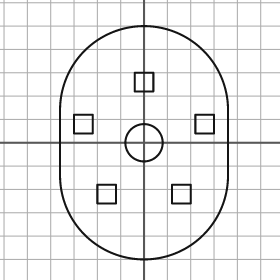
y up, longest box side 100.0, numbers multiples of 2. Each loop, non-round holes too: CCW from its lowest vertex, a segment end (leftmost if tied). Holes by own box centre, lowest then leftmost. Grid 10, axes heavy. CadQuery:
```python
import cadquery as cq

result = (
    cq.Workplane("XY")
    .moveTo(-36.0, -14.0)
    .threePointArc((0.0, -50.0), (36.0, -14.0))
    .lineTo(36.0, 14.0)
    .threePointArc((0.0, 50.0), (-36.0, 14.0))
    .close()
    .moveTo(-20.0, -26.0)
    .lineTo(-12.0, -26.0)
    .lineTo(-12.0, -18.0)
    .lineTo(-20.0, -18.0)
    .close()
    .moveTo(12.0, -26.0)
    .lineTo(20.0, -26.0)
    .lineTo(20.0, -18.0)
    .lineTo(12.0, -18.0)
    .close()
    .moveTo(0.0, 0.0)
    .circle(8.0)
    .moveTo(-30.0, 4.0)
    .lineTo(-22.0, 4.0)
    .lineTo(-22.0, 12.0)
    .lineTo(-30.0, 12.0)
    .close()
    .moveTo(22.0, 4.0)
    .lineTo(30.0, 4.0)
    .lineTo(30.0, 12.0)
    .lineTo(22.0, 12.0)
    .close()
    .moveTo(-4.0, 22.0)
    .lineTo(4.0, 22.0)
    .lineTo(4.0, 30.0)
    .lineTo(-4.0, 30.0)
    .close()
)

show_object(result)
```